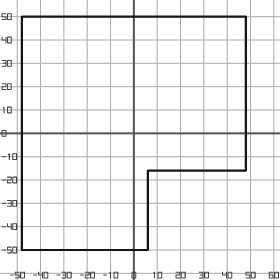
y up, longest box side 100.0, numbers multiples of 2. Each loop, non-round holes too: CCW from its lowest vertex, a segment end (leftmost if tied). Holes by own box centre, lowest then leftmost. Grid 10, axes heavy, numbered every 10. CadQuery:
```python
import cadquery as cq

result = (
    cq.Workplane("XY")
    .moveTo(-48.0, -50.0)
    .lineTo(6.0, -50.0)
    .lineTo(6.0, -16.0)
    .lineTo(48.0, -16.0)
    .lineTo(48.0, 50.0)
    .lineTo(-48.0, 50.0)
    .close()
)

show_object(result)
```